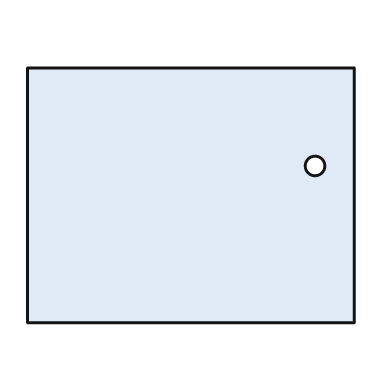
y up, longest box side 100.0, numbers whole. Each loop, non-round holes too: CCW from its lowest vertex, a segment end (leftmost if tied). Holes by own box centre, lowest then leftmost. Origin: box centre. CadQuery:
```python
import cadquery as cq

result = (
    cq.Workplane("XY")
    .moveTo(-50.0, -39.0)
    .lineTo(50.0, -39.0)
    .lineTo(50.0, 39.0)
    .lineTo(-50.0, 39.0)
    .close()
    .moveTo(38.0, 9.0)
    .circle(3.0)
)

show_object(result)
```